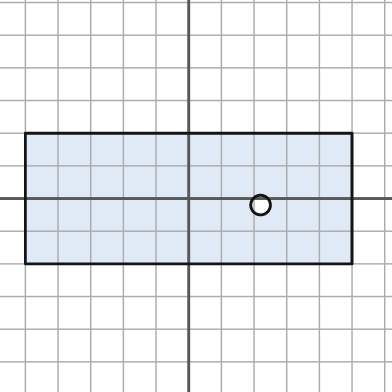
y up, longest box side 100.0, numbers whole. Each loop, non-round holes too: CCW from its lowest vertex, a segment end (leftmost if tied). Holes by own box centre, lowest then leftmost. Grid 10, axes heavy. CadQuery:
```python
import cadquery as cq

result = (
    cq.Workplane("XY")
    .moveTo(-50.0, -20.0)
    .lineTo(50.0, -20.0)
    .lineTo(50.0, 20.0)
    .lineTo(-50.0, 20.0)
    .close()
    .moveTo(22.0, -2.0)
    .circle(3.0)
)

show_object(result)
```